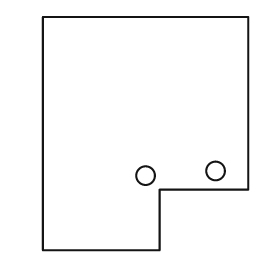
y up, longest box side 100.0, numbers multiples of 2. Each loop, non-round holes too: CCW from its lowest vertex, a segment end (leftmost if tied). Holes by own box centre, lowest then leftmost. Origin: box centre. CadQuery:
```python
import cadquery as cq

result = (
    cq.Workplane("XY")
    .moveTo(-44.0, -50.0)
    .lineTo(6.0, -50.0)
    .lineTo(6.0, -24.0)
    .lineTo(44.0, -24.0)
    .lineTo(44.0, 50.0)
    .lineTo(-44.0, 50.0)
    .close()
    .moveTo(0.0, -18.0)
    .circle(4.0)
    .moveTo(30.0, -16.0)
    .circle(4.0)
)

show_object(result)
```